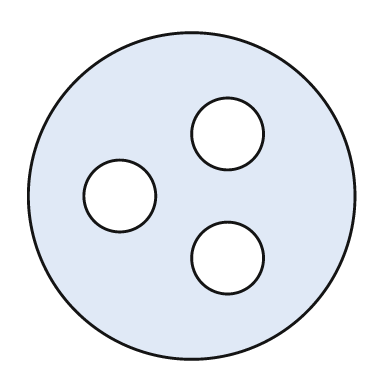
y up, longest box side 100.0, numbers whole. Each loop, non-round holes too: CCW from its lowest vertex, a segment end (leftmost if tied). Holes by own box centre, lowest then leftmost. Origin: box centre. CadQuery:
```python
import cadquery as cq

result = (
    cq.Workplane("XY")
    .moveTo(0.0, 0.0)
    .circle(50.0)
    .moveTo(11.0, -19.0)
    .circle(11.0)
    .moveTo(-22.0, 0.0)
    .circle(11.0)
    .moveTo(11.0, 19.0)
    .circle(11.0)
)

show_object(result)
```